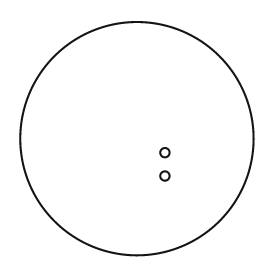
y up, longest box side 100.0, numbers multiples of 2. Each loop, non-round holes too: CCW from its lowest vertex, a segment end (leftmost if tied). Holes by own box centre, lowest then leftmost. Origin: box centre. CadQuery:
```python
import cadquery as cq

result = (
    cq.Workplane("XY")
    .moveTo(0.0, 0.0)
    .circle(50.0)
    .moveTo(12.0, -16.0)
    .circle(2.0)
    .moveTo(12.0, -6.0)
    .circle(2.0)
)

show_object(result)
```